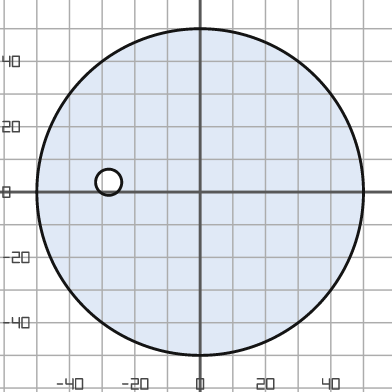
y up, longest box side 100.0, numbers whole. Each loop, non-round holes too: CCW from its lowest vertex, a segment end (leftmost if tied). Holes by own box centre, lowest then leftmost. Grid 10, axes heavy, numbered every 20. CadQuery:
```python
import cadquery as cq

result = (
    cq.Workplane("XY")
    .moveTo(0.0, 0.0)
    .circle(50.0)
    .moveTo(-28.0, 3.0)
    .circle(4.0)
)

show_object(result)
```